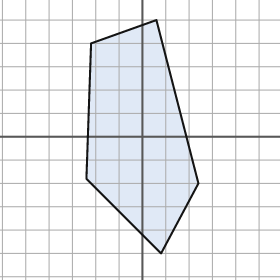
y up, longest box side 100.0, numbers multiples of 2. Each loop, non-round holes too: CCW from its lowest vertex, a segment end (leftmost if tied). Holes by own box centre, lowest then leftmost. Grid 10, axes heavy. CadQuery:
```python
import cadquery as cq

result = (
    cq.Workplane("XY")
    .moveTo(8.0, -50.0)
    .lineTo(24.0, -20.0)
    .lineTo(6.0, 50.0)
    .lineTo(-22.0, 40.0)
    .lineTo(-24.0, -18.0)
    .close()
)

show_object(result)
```